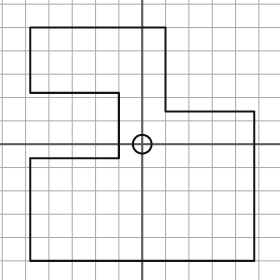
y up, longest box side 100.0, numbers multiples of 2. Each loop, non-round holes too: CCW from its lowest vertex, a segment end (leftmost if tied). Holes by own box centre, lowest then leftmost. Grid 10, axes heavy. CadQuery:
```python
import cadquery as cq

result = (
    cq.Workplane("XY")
    .moveTo(-48.0, -50.0)
    .lineTo(48.0, -50.0)
    .lineTo(48.0, 14.0)
    .lineTo(10.0, 14.0)
    .lineTo(10.0, 50.0)
    .lineTo(-48.0, 50.0)
    .lineTo(-48.0, 22.0)
    .lineTo(-10.0, 22.0)
    .lineTo(-10.0, -6.0)
    .lineTo(-48.0, -6.0)
    .close()
    .moveTo(0.0, 0.0)
    .circle(4.0)
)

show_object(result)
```